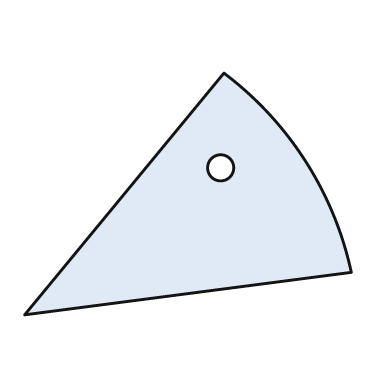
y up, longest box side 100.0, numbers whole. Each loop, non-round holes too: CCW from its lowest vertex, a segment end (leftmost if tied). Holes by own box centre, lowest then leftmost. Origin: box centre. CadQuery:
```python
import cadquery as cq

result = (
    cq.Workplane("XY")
    .moveTo(-50.0, -37.0)
    .lineTo(50.0, -24.0)
    .threePointArc((36.0, 10.0), (11.0, 37.0))
    .close()
    .moveTo(10.0, 8.0)
    .circle(4.0)
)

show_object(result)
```